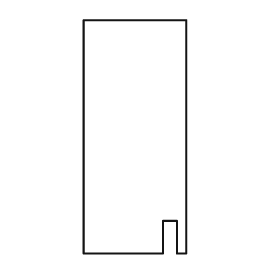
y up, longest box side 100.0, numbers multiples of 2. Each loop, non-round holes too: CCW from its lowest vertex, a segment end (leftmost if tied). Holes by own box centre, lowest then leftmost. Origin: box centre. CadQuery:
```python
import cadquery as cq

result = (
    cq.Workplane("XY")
    .moveTo(-22.0, -50.0)
    .lineTo(12.0, -50.0)
    .lineTo(12.0, -36.0)
    .lineTo(18.0, -36.0)
    .lineTo(18.0, -50.0)
    .lineTo(22.0, -50.0)
    .lineTo(22.0, 50.0)
    .lineTo(-22.0, 50.0)
    .close()
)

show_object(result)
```